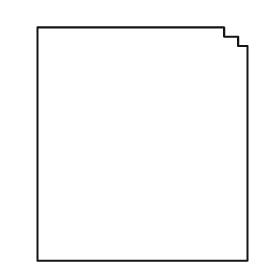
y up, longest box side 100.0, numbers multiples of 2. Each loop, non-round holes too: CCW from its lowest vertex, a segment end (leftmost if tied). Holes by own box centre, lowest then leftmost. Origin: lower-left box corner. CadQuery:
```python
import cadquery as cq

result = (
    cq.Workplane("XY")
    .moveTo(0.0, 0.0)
    .lineTo(90.0, 0.0)
    .lineTo(90.0, 92.0)
    .lineTo(86.0, 92.0)
    .lineTo(86.0, 96.0)
    .lineTo(80.0, 96.0)
    .lineTo(80.0, 100.0)
    .lineTo(0.0, 100.0)
    .close()
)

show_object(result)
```